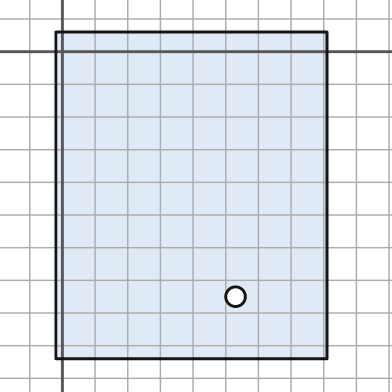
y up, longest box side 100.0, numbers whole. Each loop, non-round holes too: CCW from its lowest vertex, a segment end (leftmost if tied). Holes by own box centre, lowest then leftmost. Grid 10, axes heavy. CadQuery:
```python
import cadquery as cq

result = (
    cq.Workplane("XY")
    .moveTo(-2.0, -94.0)
    .lineTo(81.0, -94.0)
    .lineTo(81.0, 6.0)
    .lineTo(-2.0, 6.0)
    .close()
    .moveTo(53.0, -75.0)
    .circle(3.0)
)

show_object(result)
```